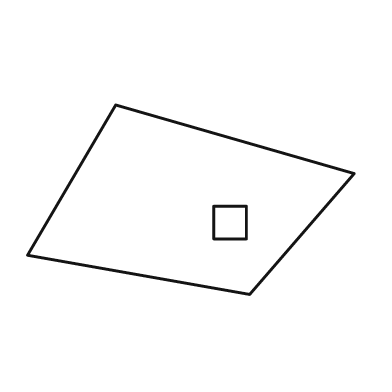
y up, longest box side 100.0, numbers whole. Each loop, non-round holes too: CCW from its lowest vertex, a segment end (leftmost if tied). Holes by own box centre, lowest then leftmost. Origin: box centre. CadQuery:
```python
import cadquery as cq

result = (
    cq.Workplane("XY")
    .moveTo(18.0, -29.0)
    .lineTo(50.0, 8.0)
    .lineTo(-23.0, 29.0)
    .lineTo(-50.0, -17.0)
    .close()
    .moveTo(7.0, -12.0)
    .lineTo(17.0, -12.0)
    .lineTo(17.0, -2.0)
    .lineTo(7.0, -2.0)
    .close()
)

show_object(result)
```